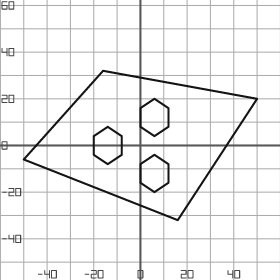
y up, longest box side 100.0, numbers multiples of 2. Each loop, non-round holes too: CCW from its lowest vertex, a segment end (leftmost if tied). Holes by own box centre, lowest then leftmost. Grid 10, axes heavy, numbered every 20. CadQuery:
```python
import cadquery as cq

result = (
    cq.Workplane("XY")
    .moveTo(16.0, -32.0)
    .lineTo(50.0, 20.0)
    .lineTo(-16.0, 32.0)
    .lineTo(-50.0, -6.0)
    .close()
    .moveTo(6.0, -20.0)
    .lineTo(12.0, -16.0)
    .lineTo(12.0, -8.0)
    .lineTo(6.0, -4.0)
    .lineTo(0.0, -8.0)
    .lineTo(0.0, -16.0)
    .close()
    .moveTo(-14.0, -8.0)
    .lineTo(-8.0, -4.0)
    .lineTo(-8.0, 4.0)
    .lineTo(-14.0, 8.0)
    .lineTo(-20.0, 4.0)
    .lineTo(-20.0, -4.0)
    .close()
    .moveTo(6.0, 4.0)
    .lineTo(12.0, 8.0)
    .lineTo(12.0, 16.0)
    .lineTo(6.0, 20.0)
    .lineTo(0.0, 16.0)
    .lineTo(0.0, 8.0)
    .close()
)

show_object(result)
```